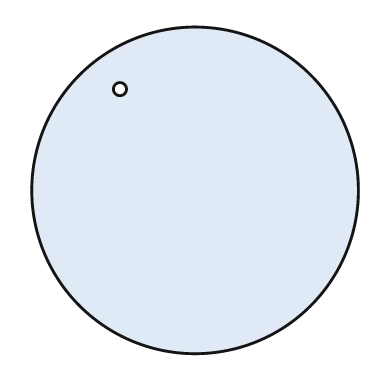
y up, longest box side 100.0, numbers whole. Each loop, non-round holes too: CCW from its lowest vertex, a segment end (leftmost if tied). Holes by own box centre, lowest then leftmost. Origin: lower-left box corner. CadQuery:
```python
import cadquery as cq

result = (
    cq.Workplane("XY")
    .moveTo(50.0, 50.0)
    .circle(50.0)
    .moveTo(27.0, 81.0)
    .circle(2.0)
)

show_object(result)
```